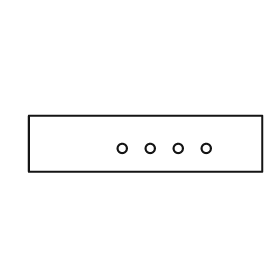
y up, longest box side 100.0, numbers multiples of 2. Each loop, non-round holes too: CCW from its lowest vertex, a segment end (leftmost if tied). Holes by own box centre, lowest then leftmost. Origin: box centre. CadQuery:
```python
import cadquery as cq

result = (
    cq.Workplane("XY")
    .moveTo(-50.0, -12.0)
    .lineTo(50.0, -12.0)
    .lineTo(50.0, 12.0)
    .lineTo(-50.0, 12.0)
    .close()
    .moveTo(-10.0, -2.0)
    .circle(2.0)
    .moveTo(2.0, -2.0)
    .circle(2.0)
    .moveTo(14.0, -2.0)
    .circle(2.0)
    .moveTo(26.0, -2.0)
    .circle(2.0)
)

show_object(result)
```